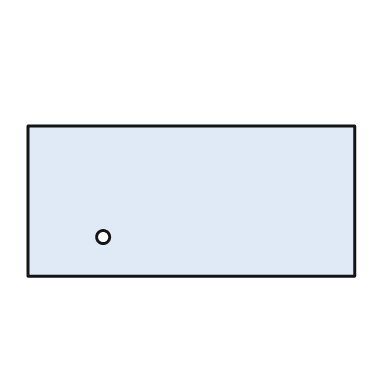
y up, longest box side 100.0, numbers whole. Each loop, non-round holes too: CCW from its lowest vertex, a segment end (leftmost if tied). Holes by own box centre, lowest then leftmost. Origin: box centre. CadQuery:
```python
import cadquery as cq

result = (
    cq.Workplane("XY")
    .moveTo(-50.0, -23.0)
    .lineTo(50.0, -23.0)
    .lineTo(50.0, 23.0)
    .lineTo(-50.0, 23.0)
    .close()
    .moveTo(-27.0, -11.0)
    .circle(2.0)
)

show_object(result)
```